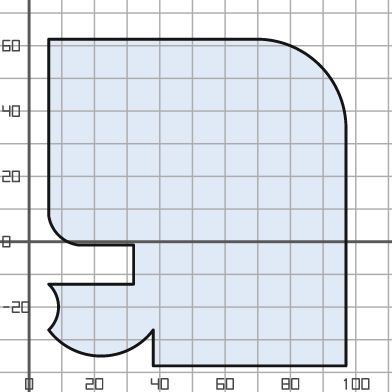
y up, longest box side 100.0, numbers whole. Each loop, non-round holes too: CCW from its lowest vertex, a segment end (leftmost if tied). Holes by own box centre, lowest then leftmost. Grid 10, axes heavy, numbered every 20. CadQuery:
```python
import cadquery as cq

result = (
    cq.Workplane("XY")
    .moveTo(38.0, -38.0)
    .lineTo(97.0, -38.0)
    .lineTo(97.0, 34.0)
    .threePointArc((89.0, 54.0), (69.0, 62.0))
    .lineTo(6.0, 62.0)
    .lineTo(6.0, 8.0)
    .threePointArc((9.0, 2.0), (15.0, -1.0))
    .lineTo(32.0, -1.0)
    .lineTo(32.0, -13.0)
    .lineTo(6.0, -13.0)
    .threePointArc((9.0, -20.0), (6.0, -27.0))
    .threePointArc((22.0, -35.0), (38.0, -27.0))
    .close()
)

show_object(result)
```